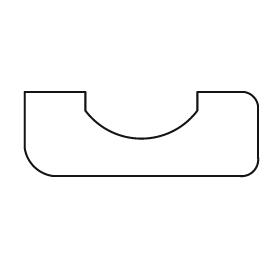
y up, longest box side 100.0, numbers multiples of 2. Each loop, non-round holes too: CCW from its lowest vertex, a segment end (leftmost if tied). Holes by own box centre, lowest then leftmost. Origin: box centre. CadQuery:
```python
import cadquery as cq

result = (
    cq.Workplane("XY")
    .moveTo(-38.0, -18.0)
    .lineTo(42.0, -18.0)
    .threePointArc((48.0, -16.0), (50.0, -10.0))
    .lineTo(50.0, 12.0)
    .threePointArc((48.0, 16.0), (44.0, 18.0))
    .lineTo(24.0, 18.0)
    .lineTo(24.0, 10.0)
    .threePointArc((0.0, -2.0), (-24.0, 10.0))
    .lineTo(-24.0, 18.0)
    .lineTo(-50.0, 18.0)
    .lineTo(-50.0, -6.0)
    .threePointArc((-46.0, -14.0), (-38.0, -18.0))
    .close()
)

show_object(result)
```